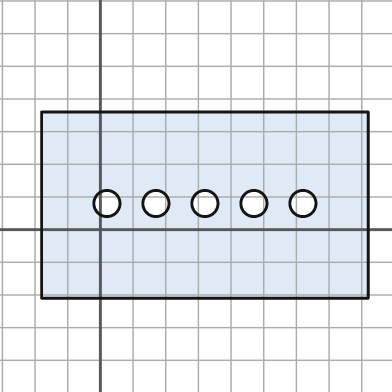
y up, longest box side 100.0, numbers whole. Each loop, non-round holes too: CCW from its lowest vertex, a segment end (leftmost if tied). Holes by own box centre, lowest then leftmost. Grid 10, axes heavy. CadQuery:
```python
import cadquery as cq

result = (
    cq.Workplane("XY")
    .moveTo(-18.0, -21.0)
    .lineTo(82.0, -21.0)
    .lineTo(82.0, 36.0)
    .lineTo(-18.0, 36.0)
    .close()
    .moveTo(2.0, 8.0)
    .circle(4.0)
    .moveTo(17.0, 8.0)
    .circle(4.0)
    .moveTo(32.0, 8.0)
    .circle(4.0)
    .moveTo(47.0, 8.0)
    .circle(4.0)
    .moveTo(62.0, 8.0)
    .circle(4.0)
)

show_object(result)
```